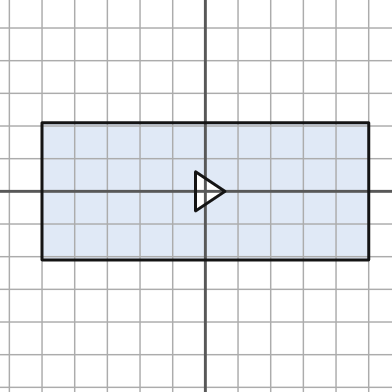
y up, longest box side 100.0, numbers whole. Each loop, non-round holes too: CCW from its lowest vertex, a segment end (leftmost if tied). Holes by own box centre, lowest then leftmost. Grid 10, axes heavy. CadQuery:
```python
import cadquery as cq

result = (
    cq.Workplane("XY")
    .moveTo(-50.0, -21.0)
    .lineTo(50.0, -21.0)
    .lineTo(50.0, 21.0)
    .lineTo(-50.0, 21.0)
    .close()
    .moveTo(-3.0, -6.0)
    .lineTo(6.0, 0.0)
    .lineTo(-3.0, 6.0)
    .close()
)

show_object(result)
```